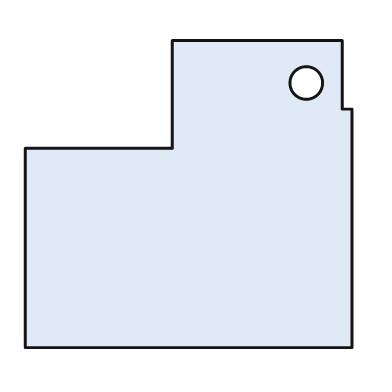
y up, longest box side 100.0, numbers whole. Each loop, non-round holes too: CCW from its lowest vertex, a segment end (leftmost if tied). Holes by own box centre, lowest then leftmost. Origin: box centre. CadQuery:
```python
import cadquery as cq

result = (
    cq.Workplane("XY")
    .moveTo(-50.0, -47.0)
    .lineTo(50.0, -47.0)
    .lineTo(50.0, 26.0)
    .lineTo(47.0, 26.0)
    .lineTo(47.0, 47.0)
    .lineTo(-5.0, 47.0)
    .lineTo(-5.0, 14.0)
    .lineTo(-50.0, 14.0)
    .close()
    .moveTo(36.0, 34.0)
    .circle(5.0)
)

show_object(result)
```